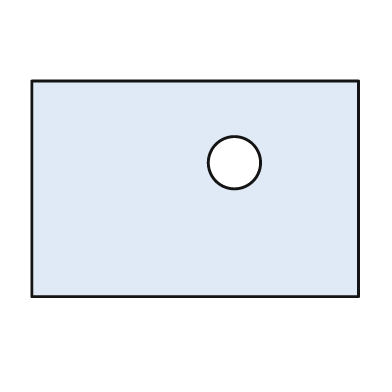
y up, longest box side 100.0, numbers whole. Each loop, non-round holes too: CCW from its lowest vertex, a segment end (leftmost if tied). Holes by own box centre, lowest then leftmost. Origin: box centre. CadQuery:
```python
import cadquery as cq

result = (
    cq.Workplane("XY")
    .moveTo(-50.0, -33.0)
    .lineTo(50.0, -33.0)
    .lineTo(50.0, 33.0)
    .lineTo(-50.0, 33.0)
    .close()
    .moveTo(12.0, 8.0)
    .circle(8.0)
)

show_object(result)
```